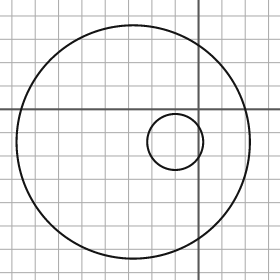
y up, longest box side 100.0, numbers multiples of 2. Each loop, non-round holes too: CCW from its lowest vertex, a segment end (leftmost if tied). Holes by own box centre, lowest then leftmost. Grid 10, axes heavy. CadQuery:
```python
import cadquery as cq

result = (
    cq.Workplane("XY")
    .moveTo(-28.0, -14.0)
    .circle(50.0)
    .moveTo(-10.0, -14.0)
    .circle(12.0)
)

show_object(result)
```